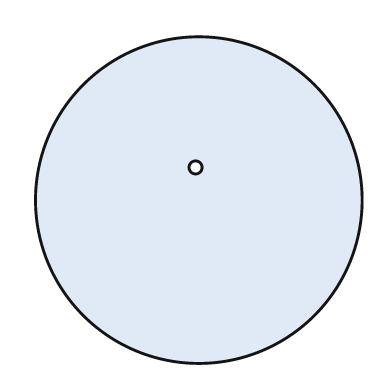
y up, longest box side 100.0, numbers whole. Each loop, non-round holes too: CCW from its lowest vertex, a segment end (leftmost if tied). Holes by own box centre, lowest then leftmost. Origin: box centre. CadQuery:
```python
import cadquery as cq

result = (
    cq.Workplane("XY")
    .moveTo(0.0, 0.0)
    .circle(50.0)
    .moveTo(-1.0, 10.0)
    .circle(2.0)
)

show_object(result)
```